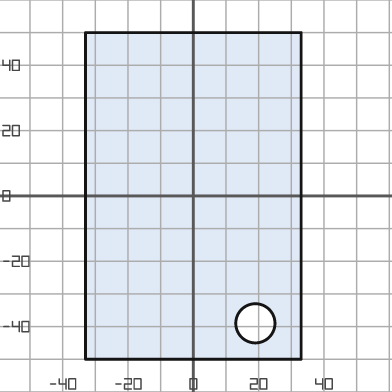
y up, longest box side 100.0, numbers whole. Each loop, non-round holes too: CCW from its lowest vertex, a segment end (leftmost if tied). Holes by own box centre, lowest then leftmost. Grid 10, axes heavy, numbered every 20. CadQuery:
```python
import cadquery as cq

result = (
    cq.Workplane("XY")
    .moveTo(-33.0, -50.0)
    .lineTo(33.0, -50.0)
    .lineTo(33.0, 50.0)
    .lineTo(-33.0, 50.0)
    .close()
    .moveTo(19.0, -39.0)
    .circle(6.0)
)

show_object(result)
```